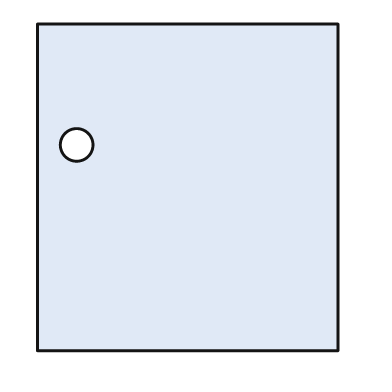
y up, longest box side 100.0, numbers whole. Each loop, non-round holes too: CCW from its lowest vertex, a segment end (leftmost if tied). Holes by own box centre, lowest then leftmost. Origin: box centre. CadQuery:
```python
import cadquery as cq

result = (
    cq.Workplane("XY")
    .moveTo(-46.0, -50.0)
    .lineTo(46.0, -50.0)
    .lineTo(46.0, 50.0)
    .lineTo(-46.0, 50.0)
    .close()
    .moveTo(-34.0, 13.0)
    .circle(5.0)
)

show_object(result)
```